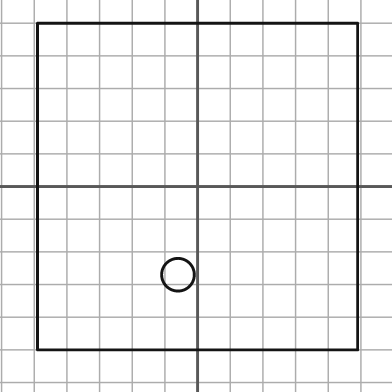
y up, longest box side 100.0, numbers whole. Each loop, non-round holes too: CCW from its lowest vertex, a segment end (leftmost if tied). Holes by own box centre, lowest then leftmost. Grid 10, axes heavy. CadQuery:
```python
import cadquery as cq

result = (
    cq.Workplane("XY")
    .moveTo(-49.0, -50.0)
    .lineTo(49.0, -50.0)
    .lineTo(49.0, 50.0)
    .lineTo(-49.0, 50.0)
    .close()
    .moveTo(-6.0, -27.0)
    .circle(5.0)
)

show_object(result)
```